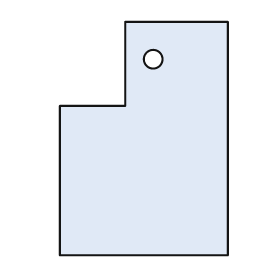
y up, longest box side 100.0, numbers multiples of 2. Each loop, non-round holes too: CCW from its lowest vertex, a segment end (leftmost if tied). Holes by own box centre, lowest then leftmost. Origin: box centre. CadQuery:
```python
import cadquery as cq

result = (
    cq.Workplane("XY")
    .moveTo(-36.0, -50.0)
    .lineTo(36.0, -50.0)
    .lineTo(36.0, 50.0)
    .lineTo(-8.0, 50.0)
    .lineTo(-8.0, 14.0)
    .lineTo(-36.0, 14.0)
    .close()
    .moveTo(4.0, 34.0)
    .circle(4.0)
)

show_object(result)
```